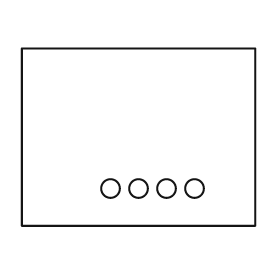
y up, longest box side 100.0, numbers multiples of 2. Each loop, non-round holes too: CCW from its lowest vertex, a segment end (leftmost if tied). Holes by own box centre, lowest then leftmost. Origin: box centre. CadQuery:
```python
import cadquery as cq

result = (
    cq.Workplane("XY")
    .moveTo(-50.0, -38.0)
    .lineTo(50.0, -38.0)
    .lineTo(50.0, 38.0)
    .lineTo(-50.0, 38.0)
    .close()
    .moveTo(-12.0, -22.0)
    .circle(4.0)
    .moveTo(0.0, -22.0)
    .circle(4.0)
    .moveTo(12.0, -22.0)
    .circle(4.0)
    .moveTo(24.0, -22.0)
    .circle(4.0)
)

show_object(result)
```